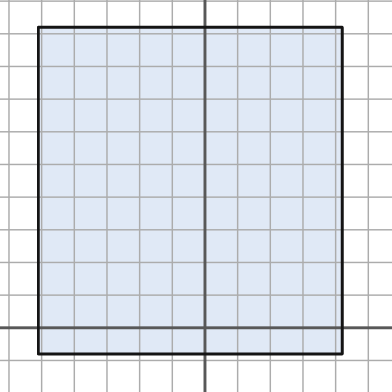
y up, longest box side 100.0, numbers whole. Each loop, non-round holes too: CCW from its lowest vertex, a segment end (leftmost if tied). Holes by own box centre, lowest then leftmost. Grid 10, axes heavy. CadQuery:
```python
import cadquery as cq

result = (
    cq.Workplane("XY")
    .moveTo(-51.0, -8.0)
    .lineTo(42.0, -8.0)
    .lineTo(42.0, 92.0)
    .lineTo(-51.0, 92.0)
    .close()
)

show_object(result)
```